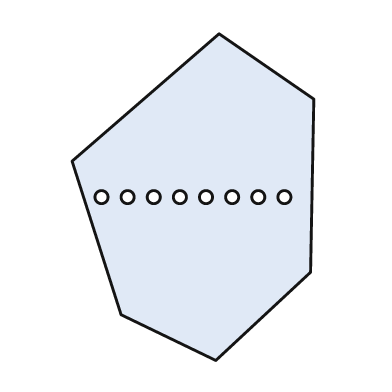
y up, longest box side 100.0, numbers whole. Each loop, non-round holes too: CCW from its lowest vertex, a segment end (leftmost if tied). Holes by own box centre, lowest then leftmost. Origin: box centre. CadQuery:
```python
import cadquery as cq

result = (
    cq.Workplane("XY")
    .moveTo(7.0, -50.0)
    .lineTo(36.0, -23.0)
    .lineTo(37.0, 30.0)
    .lineTo(8.0, 50.0)
    .lineTo(-37.0, 11.0)
    .lineTo(-22.0, -36.0)
    .close()
    .moveTo(-28.0, 0.0)
    .circle(2.0)
    .moveTo(-20.0, 0.0)
    .circle(2.0)
    .moveTo(-12.0, 0.0)
    .circle(2.0)
    .moveTo(-4.0, 0.0)
    .circle(2.0)
    .moveTo(4.0, 0.0)
    .circle(2.0)
    .moveTo(12.0, 0.0)
    .circle(2.0)
    .moveTo(20.0, 0.0)
    .circle(2.0)
    .moveTo(28.0, 0.0)
    .circle(2.0)
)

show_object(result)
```